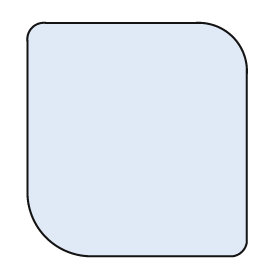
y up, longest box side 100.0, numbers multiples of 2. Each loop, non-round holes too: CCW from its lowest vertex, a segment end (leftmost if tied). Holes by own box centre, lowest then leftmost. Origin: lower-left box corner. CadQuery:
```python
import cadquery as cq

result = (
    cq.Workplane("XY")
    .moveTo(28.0, 0.0)
    .lineTo(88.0, 0.0)
    .threePointArc((92.0, 2.0), (94.0, 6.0))
    .lineTo(94.0, 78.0)
    .threePointArc((88.0, 94.0), (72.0, 100.0))
    .lineTo(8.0, 100.0)
    .threePointArc((2.0, 98.0), (0.0, 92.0))
    .lineTo(0.0, 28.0)
    .threePointArc((8.0, 8.0), (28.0, 0.0))
    .close()
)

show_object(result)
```